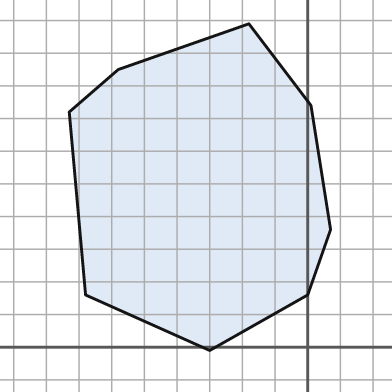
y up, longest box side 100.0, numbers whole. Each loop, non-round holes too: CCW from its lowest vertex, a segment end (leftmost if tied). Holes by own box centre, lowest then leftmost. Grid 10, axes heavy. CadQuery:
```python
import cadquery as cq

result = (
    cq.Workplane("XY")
    .moveTo(-30.0, -1.0)
    .lineTo(0.0, 16.0)
    .lineTo(7.0, 36.0)
    .lineTo(1.0, 74.0)
    .lineTo(-18.0, 99.0)
    .lineTo(-58.0, 85.0)
    .lineTo(-73.0, 72.0)
    .lineTo(-68.0, 16.0)
    .close()
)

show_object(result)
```